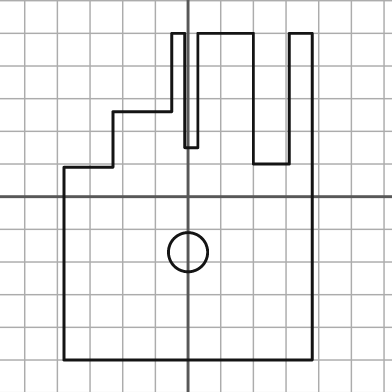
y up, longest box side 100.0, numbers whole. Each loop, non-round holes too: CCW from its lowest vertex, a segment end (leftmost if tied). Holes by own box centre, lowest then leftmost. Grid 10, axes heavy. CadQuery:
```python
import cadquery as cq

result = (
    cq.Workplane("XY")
    .moveTo(-38.0, -50.0)
    .lineTo(38.0, -50.0)
    .lineTo(38.0, 50.0)
    .lineTo(31.0, 50.0)
    .lineTo(31.0, 10.0)
    .lineTo(20.0, 10.0)
    .lineTo(20.0, 50.0)
    .lineTo(3.0, 50.0)
    .lineTo(3.0, 15.0)
    .lineTo(-1.0, 15.0)
    .lineTo(-1.0, 50.0)
    .lineTo(-5.0, 50.0)
    .lineTo(-5.0, 26.0)
    .lineTo(-23.0, 26.0)
    .lineTo(-23.0, 9.0)
    .lineTo(-38.0, 9.0)
    .close()
    .moveTo(0.0, -17.0)
    .circle(6.0)
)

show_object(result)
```